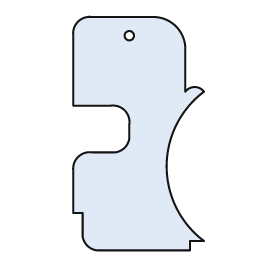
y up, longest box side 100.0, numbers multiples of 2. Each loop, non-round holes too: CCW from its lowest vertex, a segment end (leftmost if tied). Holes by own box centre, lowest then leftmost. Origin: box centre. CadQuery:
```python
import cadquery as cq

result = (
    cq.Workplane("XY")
    .moveTo(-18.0, -50.0)
    .lineTo(22.0, -50.0)
    .lineTo(22.0, -46.0)
    .lineTo(28.0, -46.0)
    .threePointArc((12.0, -14.0), (28.0, 18.0))
    .threePointArc((24.0, 20.0), (20.0, 18.0))
    .lineTo(20.0, 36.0)
    .threePointArc((16.0, 46.0), (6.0, 50.0))
    .lineTo(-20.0, 50.0)
    .threePointArc((-26.0, 48.0), (-28.0, 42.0))
    .lineTo(-28.0, 12.0)
    .lineTo(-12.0, 12.0)
    .threePointArc((-6.0, 10.0), (-4.0, 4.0))
    .lineTo(-4.0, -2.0)
    .threePointArc((-6.0, -6.0), (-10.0, -8.0))
    .lineTo(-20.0, -8.0)
    .threePointArc((-26.0, -10.0), (-28.0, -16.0))
    .lineTo(-28.0, -34.0)
    .lineTo(-24.0, -34.0)
    .lineTo(-24.0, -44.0)
    .threePointArc((-22.0, -48.0), (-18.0, -50.0))
    .close()
    .moveTo(-4.0, 42.0)
    .circle(2.0)
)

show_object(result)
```